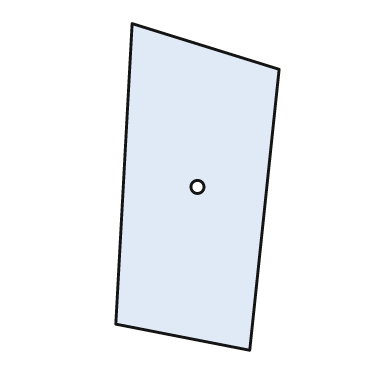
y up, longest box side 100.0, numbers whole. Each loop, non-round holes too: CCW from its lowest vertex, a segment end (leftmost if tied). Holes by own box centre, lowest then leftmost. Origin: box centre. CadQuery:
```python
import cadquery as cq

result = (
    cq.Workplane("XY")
    .moveTo(16.0, -50.0)
    .lineTo(25.0, 36.0)
    .lineTo(-20.0, 50.0)
    .lineTo(-25.0, -42.0)
    .close()
    .moveTo(0.0, 0.0)
    .circle(2.0)
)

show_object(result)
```